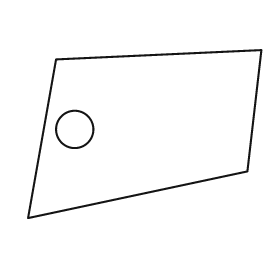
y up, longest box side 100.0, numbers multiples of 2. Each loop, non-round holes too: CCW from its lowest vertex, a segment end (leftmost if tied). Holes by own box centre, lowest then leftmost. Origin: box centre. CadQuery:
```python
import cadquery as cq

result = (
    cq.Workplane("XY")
    .moveTo(-50.0, -36.0)
    .lineTo(44.0, -16.0)
    .lineTo(50.0, 36.0)
    .lineTo(-38.0, 32.0)
    .close()
    .moveTo(-30.0, 2.0)
    .circle(8.0)
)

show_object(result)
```